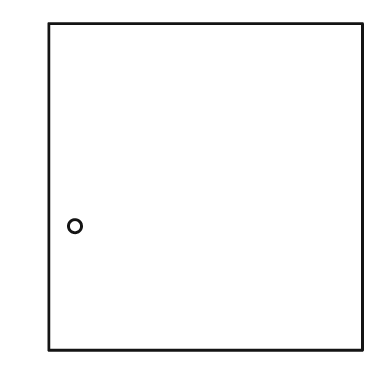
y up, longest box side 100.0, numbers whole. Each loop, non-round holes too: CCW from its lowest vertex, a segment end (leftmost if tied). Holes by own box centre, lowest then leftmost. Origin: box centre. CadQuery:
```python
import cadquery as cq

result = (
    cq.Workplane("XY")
    .moveTo(-48.0, -50.0)
    .lineTo(48.0, -50.0)
    .lineTo(48.0, 50.0)
    .lineTo(-48.0, 50.0)
    .close()
    .moveTo(-40.0, -12.0)
    .circle(2.0)
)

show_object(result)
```